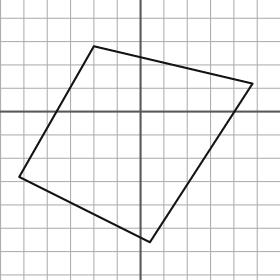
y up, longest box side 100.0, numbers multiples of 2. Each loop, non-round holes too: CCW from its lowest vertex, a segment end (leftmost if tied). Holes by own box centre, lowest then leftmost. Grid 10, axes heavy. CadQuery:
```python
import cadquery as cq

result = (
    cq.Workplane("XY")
    .moveTo(4.0, -56.0)
    .lineTo(48.0, 12.0)
    .lineTo(-20.0, 28.0)
    .lineTo(-52.0, -28.0)
    .close()
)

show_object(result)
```